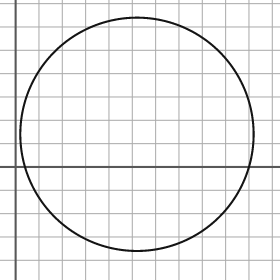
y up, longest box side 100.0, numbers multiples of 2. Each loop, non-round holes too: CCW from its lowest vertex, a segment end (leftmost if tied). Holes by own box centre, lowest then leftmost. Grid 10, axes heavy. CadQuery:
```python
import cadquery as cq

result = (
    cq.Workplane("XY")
    .moveTo(52.0, 14.0)
    .circle(50.0)
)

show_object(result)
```